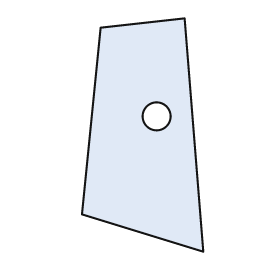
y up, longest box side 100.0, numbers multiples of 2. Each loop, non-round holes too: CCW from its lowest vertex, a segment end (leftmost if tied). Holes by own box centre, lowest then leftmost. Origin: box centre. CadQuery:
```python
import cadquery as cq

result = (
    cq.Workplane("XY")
    .moveTo(26.0, -50.0)
    .lineTo(18.0, 50.0)
    .lineTo(-18.0, 46.0)
    .lineTo(-26.0, -34.0)
    .close()
    .moveTo(6.0, 8.0)
    .circle(6.0)
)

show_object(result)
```